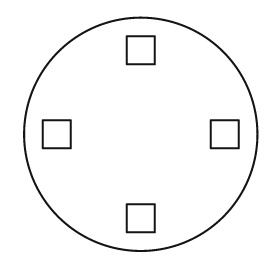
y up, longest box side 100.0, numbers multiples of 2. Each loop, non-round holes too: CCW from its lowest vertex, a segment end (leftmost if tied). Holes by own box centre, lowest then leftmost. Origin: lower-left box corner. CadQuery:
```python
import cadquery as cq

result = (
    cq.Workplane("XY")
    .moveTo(50.0, 50.0)
    .circle(50.0)
    .moveTo(44.0, 8.0)
    .lineTo(56.0, 8.0)
    .lineTo(56.0, 20.0)
    .lineTo(44.0, 20.0)
    .close()
    .moveTo(8.0, 44.0)
    .lineTo(20.0, 44.0)
    .lineTo(20.0, 56.0)
    .lineTo(8.0, 56.0)
    .close()
    .moveTo(80.0, 44.0)
    .lineTo(92.0, 44.0)
    .lineTo(92.0, 56.0)
    .lineTo(80.0, 56.0)
    .close()
    .moveTo(44.0, 80.0)
    .lineTo(56.0, 80.0)
    .lineTo(56.0, 92.0)
    .lineTo(44.0, 92.0)
    .close()
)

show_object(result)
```